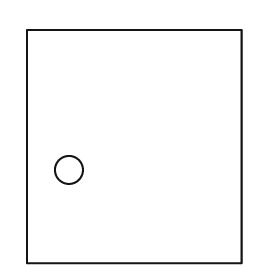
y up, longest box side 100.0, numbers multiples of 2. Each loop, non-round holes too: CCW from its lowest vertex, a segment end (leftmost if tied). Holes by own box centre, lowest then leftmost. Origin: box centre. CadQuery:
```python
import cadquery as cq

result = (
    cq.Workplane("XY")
    .moveTo(-46.0, -50.0)
    .lineTo(46.0, -50.0)
    .lineTo(46.0, 50.0)
    .lineTo(-46.0, 50.0)
    .close()
    .moveTo(-28.0, -10.0)
    .circle(6.0)
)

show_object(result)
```